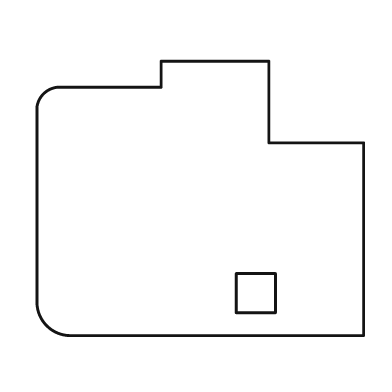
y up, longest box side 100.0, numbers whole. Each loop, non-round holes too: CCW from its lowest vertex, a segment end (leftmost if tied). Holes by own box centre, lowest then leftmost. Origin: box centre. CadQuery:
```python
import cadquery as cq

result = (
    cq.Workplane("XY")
    .moveTo(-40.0, -42.0)
    .lineTo(50.0, -42.0)
    .lineTo(50.0, 17.0)
    .lineTo(21.0, 17.0)
    .lineTo(21.0, 42.0)
    .lineTo(-12.0, 42.0)
    .lineTo(-12.0, 34.0)
    .lineTo(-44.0, 34.0)
    .threePointArc((-48.0, 32.0), (-50.0, 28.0))
    .lineTo(-50.0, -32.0)
    .threePointArc((-47.0, -39.0), (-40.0, -42.0))
    .close()
    .moveTo(11.0, -35.0)
    .lineTo(23.0, -35.0)
    .lineTo(23.0, -23.0)
    .lineTo(11.0, -23.0)
    .close()
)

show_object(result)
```